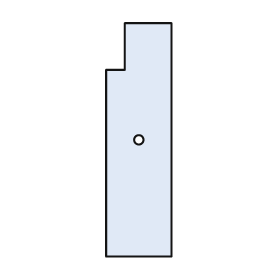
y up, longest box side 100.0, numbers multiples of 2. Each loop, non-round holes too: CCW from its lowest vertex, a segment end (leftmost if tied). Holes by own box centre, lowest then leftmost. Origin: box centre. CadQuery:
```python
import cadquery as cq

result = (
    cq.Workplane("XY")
    .moveTo(-14.0, -50.0)
    .lineTo(14.0, -50.0)
    .lineTo(14.0, 50.0)
    .lineTo(-6.0, 50.0)
    .lineTo(-6.0, 30.0)
    .lineTo(-14.0, 30.0)
    .close()
    .moveTo(0.0, 0.0)
    .circle(2.0)
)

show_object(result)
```